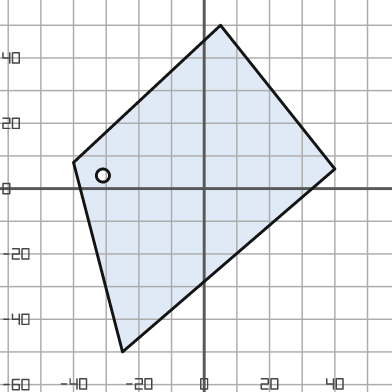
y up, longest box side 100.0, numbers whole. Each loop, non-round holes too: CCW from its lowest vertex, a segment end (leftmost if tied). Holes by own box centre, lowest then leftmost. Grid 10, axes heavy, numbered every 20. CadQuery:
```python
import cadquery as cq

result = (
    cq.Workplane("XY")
    .moveTo(-25.0, -50.0)
    .lineTo(40.0, 6.0)
    .lineTo(5.0, 50.0)
    .lineTo(-40.0, 8.0)
    .close()
    .moveTo(-31.0, 4.0)
    .circle(2.0)
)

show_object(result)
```